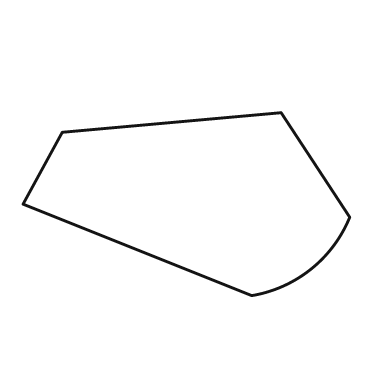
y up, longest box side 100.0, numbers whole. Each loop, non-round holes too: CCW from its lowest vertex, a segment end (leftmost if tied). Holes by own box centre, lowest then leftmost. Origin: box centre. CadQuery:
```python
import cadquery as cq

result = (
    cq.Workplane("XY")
    .moveTo(20.0, -28.0)
    .threePointArc((38.0, -20.0), (50.0, -4.0))
    .lineTo(29.0, 28.0)
    .lineTo(-38.0, 22.0)
    .lineTo(-50.0, 0.0)
    .close()
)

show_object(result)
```